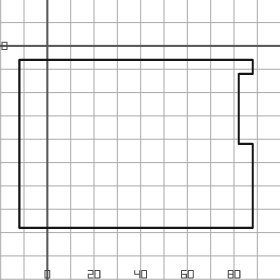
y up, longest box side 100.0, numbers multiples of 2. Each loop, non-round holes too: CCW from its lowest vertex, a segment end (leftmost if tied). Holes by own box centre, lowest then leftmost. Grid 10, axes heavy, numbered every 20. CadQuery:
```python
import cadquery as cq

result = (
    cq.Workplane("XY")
    .moveTo(-12.0, -78.0)
    .lineTo(88.0, -78.0)
    .lineTo(88.0, -42.0)
    .lineTo(82.0, -42.0)
    .lineTo(82.0, -12.0)
    .lineTo(88.0, -12.0)
    .lineTo(88.0, -6.0)
    .lineTo(-12.0, -6.0)
    .close()
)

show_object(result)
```